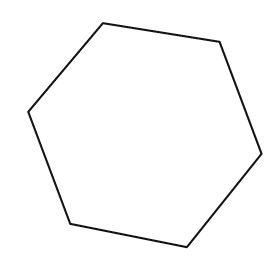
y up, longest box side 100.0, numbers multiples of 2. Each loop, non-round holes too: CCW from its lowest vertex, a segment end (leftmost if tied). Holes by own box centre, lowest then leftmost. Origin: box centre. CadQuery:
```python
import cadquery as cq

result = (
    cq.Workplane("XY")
    .moveTo(18.0, -48.0)
    .lineTo(50.0, -8.0)
    .lineTo(32.0, 40.0)
    .lineTo(-18.0, 48.0)
    .lineTo(-50.0, 10.0)
    .lineTo(-32.0, -38.0)
    .close()
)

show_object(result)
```